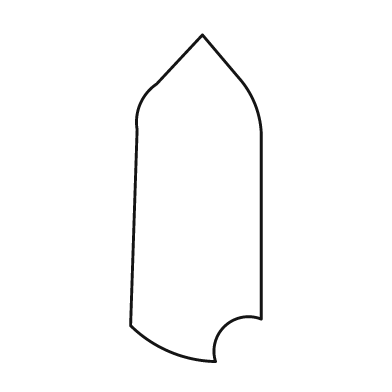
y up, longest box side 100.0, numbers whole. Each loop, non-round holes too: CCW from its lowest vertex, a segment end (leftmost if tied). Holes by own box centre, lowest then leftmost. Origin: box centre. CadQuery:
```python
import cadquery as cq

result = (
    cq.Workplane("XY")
    .moveTo(6.0, -50.0)
    .threePointArc((9.0, -39.0), (20.0, -37.0))
    .lineTo(20.0, 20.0)
    .threePointArc((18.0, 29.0), (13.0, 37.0))
    .lineTo(2.0, 50.0)
    .lineTo(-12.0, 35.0)
    .threePointArc((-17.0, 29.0), (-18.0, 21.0))
    .lineTo(-20.0, -39.0)
    .threePointArc((-8.0, -47.0), (6.0, -50.0))
    .close()
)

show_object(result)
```